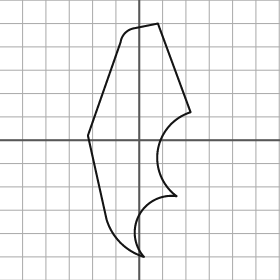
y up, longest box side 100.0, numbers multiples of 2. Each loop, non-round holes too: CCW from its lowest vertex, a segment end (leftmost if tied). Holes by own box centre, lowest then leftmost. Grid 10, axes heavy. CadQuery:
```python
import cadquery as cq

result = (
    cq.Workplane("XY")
    .moveTo(2.0, -50.0)
    .threePointArc((0.0, -32.0), (16.0, -24.0))
    .threePointArc((8.0, -4.0), (22.0, 12.0))
    .lineTo(8.0, 50.0)
    .lineTo(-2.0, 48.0)
    .threePointArc((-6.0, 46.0), (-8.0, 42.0))
    .lineTo(-22.0, 2.0)
    .lineTo(-14.0, -34.0)
    .threePointArc((-8.0, -44.0), (2.0, -50.0))
    .close()
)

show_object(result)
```